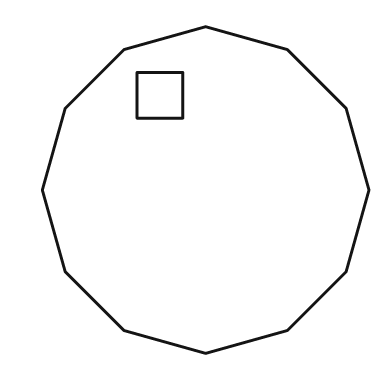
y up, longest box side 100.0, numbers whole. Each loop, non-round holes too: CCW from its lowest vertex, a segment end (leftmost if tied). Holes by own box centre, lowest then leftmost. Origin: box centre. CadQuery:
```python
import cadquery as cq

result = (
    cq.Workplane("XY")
    .moveTo(0.0, -50.0)
    .lineTo(25.0, -43.0)
    .lineTo(43.0, -25.0)
    .lineTo(50.0, 0.0)
    .lineTo(43.0, 25.0)
    .lineTo(25.0, 43.0)
    .lineTo(0.0, 50.0)
    .lineTo(-25.0, 43.0)
    .lineTo(-43.0, 25.0)
    .lineTo(-50.0, 0.0)
    .lineTo(-43.0, -25.0)
    .lineTo(-25.0, -43.0)
    .close()
    .moveTo(-21.0, 22.0)
    .lineTo(-7.0, 22.0)
    .lineTo(-7.0, 36.0)
    .lineTo(-21.0, 36.0)
    .close()
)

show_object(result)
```